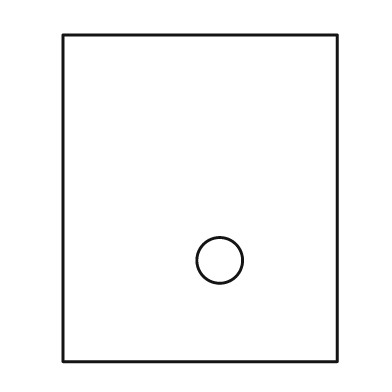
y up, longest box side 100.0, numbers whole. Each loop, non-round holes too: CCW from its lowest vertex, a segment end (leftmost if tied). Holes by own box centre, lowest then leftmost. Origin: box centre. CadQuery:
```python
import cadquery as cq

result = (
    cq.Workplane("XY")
    .moveTo(-42.0, -50.0)
    .lineTo(42.0, -50.0)
    .lineTo(42.0, 50.0)
    .lineTo(-42.0, 50.0)
    .close()
    .moveTo(6.0, -19.0)
    .circle(7.0)
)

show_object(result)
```